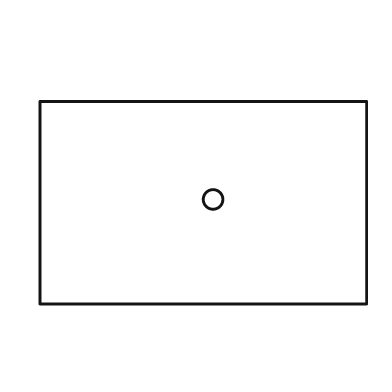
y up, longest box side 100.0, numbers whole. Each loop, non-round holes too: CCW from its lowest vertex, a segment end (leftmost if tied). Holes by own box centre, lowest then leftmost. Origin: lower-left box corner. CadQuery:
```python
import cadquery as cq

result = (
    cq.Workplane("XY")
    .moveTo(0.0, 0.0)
    .lineTo(100.0, 0.0)
    .lineTo(100.0, 62.0)
    .lineTo(0.0, 62.0)
    .close()
    .moveTo(53.0, 32.0)
    .circle(3.0)
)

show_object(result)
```